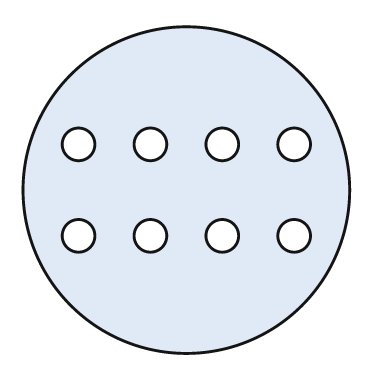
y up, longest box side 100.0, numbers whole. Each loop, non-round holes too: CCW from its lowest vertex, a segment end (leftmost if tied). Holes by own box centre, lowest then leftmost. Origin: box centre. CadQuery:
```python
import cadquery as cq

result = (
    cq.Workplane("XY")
    .moveTo(0.0, 0.0)
    .circle(50.0)
    .moveTo(-33.0, -14.0)
    .circle(5.0)
    .moveTo(-11.0, -14.0)
    .circle(5.0)
    .moveTo(11.0, -14.0)
    .circle(5.0)
    .moveTo(33.0, -14.0)
    .circle(5.0)
    .moveTo(-33.0, 14.0)
    .circle(5.0)
    .moveTo(-11.0, 14.0)
    .circle(5.0)
    .moveTo(11.0, 14.0)
    .circle(5.0)
    .moveTo(33.0, 14.0)
    .circle(5.0)
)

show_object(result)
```